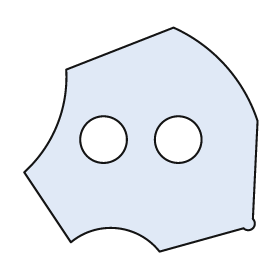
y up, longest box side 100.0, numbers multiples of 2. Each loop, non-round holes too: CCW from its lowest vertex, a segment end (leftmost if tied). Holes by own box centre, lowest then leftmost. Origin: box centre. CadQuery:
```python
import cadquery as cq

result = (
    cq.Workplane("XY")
    .moveTo(8.0, -48.0)
    .lineTo(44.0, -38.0)
    .threePointArc((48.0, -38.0), (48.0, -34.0))
    .lineTo(50.0, 8.0)
    .threePointArc((36.0, 32.0), (14.0, 48.0))
    .lineTo(-32.0, 30.0)
    .threePointArc((-36.0, 6.0), (-50.0, -14.0))
    .lineTo(-30.0, -44.0)
    .threePointArc((-10.0, -38.0), (8.0, -48.0))
    .close()
    .moveTo(-16.0, 0.0)
    .circle(10.0)
    .moveTo(16.0, 0.0)
    .circle(10.0)
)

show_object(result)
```